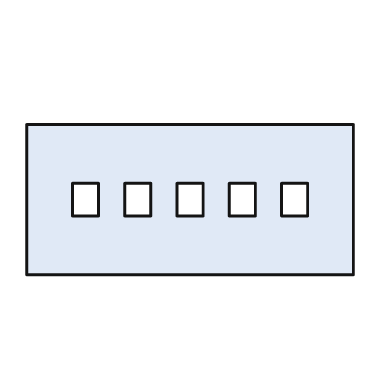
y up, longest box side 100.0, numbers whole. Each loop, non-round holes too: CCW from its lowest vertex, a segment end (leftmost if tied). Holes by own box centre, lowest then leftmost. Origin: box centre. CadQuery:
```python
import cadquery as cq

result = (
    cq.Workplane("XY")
    .moveTo(-50.0, -23.0)
    .lineTo(50.0, -23.0)
    .lineTo(50.0, 23.0)
    .lineTo(-50.0, 23.0)
    .close()
    .moveTo(-36.0, -5.0)
    .lineTo(-28.0, -5.0)
    .lineTo(-28.0, 5.0)
    .lineTo(-36.0, 5.0)
    .close()
    .moveTo(-20.0, -5.0)
    .lineTo(-12.0, -5.0)
    .lineTo(-12.0, 5.0)
    .lineTo(-20.0, 5.0)
    .close()
    .moveTo(-4.0, -5.0)
    .lineTo(4.0, -5.0)
    .lineTo(4.0, 5.0)
    .lineTo(-4.0, 5.0)
    .close()
    .moveTo(12.0, -5.0)
    .lineTo(20.0, -5.0)
    .lineTo(20.0, 5.0)
    .lineTo(12.0, 5.0)
    .close()
    .moveTo(28.0, -5.0)
    .lineTo(36.0, -5.0)
    .lineTo(36.0, 5.0)
    .lineTo(28.0, 5.0)
    .close()
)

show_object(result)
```